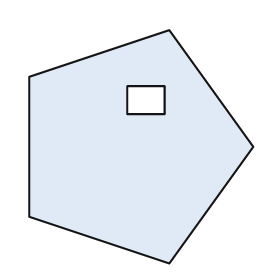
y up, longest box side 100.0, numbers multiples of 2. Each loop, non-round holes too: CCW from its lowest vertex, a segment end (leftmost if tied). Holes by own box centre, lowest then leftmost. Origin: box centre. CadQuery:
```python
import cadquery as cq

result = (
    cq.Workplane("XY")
    .moveTo(12.0, -50.0)
    .lineTo(48.0, 0.0)
    .lineTo(12.0, 50.0)
    .lineTo(-48.0, 30.0)
    .lineTo(-48.0, -30.0)
    .close()
    .moveTo(-6.0, 14.0)
    .lineTo(10.0, 14.0)
    .lineTo(10.0, 26.0)
    .lineTo(-6.0, 26.0)
    .close()
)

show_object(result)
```